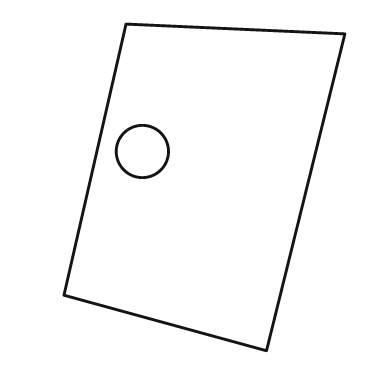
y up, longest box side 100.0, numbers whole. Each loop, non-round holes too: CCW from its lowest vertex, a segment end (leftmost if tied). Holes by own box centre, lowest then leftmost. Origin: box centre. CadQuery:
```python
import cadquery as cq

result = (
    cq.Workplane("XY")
    .moveTo(19.0, -50.0)
    .lineTo(43.0, 47.0)
    .lineTo(-24.0, 50.0)
    .lineTo(-43.0, -33.0)
    .close()
    .moveTo(-19.0, 11.0)
    .circle(8.0)
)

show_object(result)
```